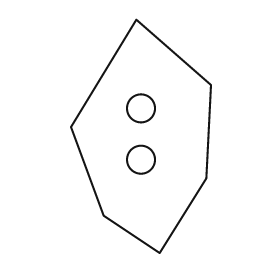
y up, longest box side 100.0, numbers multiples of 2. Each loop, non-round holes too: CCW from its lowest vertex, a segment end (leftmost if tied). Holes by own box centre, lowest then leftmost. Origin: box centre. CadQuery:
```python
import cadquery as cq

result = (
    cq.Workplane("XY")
    .moveTo(8.0, -50.0)
    .lineTo(28.0, -18.0)
    .lineTo(30.0, 22.0)
    .lineTo(-2.0, 50.0)
    .lineTo(-30.0, 4.0)
    .lineTo(-16.0, -34.0)
    .close()
    .moveTo(0.0, -10.0)
    .circle(6.0)
    .moveTo(0.0, 12.0)
    .circle(6.0)
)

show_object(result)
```